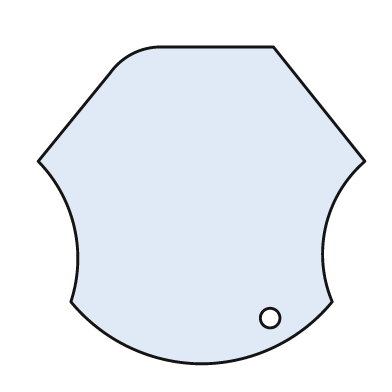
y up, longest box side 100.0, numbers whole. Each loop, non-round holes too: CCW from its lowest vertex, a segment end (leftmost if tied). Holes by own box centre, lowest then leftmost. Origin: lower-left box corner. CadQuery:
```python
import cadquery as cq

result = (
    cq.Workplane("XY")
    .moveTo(50.0, 0.0)
    .threePointArc((72.0, 5.0), (90.0, 19.0))
    .threePointArc((88.0, 42.0), (100.0, 62.0))
    .lineTo(72.0, 97.0)
    .lineTo(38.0, 97.0)
    .threePointArc((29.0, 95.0), (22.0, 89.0))
    .lineTo(0.0, 62.0)
    .threePointArc((11.0, 42.0), (10.0, 19.0))
    .threePointArc((28.0, 5.0), (50.0, 0.0))
    .close()
    .moveTo(71.0, 14.0)
    .circle(3.0)
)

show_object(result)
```